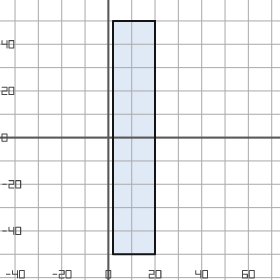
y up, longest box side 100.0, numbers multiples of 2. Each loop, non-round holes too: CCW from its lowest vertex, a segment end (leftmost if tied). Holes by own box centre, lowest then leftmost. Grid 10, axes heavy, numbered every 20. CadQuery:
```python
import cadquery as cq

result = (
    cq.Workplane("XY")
    .moveTo(2.0, -50.0)
    .lineTo(20.0, -50.0)
    .lineTo(20.0, 50.0)
    .lineTo(2.0, 50.0)
    .close()
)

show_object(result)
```